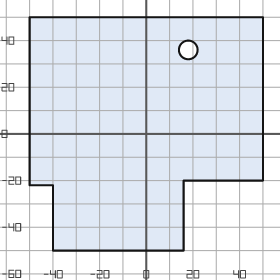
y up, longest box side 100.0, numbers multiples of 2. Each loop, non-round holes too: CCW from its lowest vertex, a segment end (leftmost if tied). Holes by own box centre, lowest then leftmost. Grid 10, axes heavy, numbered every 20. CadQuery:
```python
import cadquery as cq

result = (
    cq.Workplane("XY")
    .moveTo(-40.0, -50.0)
    .lineTo(16.0, -50.0)
    .lineTo(16.0, -20.0)
    .lineTo(50.0, -20.0)
    .lineTo(50.0, 50.0)
    .lineTo(-50.0, 50.0)
    .lineTo(-50.0, -22.0)
    .lineTo(-40.0, -22.0)
    .close()
    .moveTo(18.0, 36.0)
    .circle(4.0)
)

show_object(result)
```